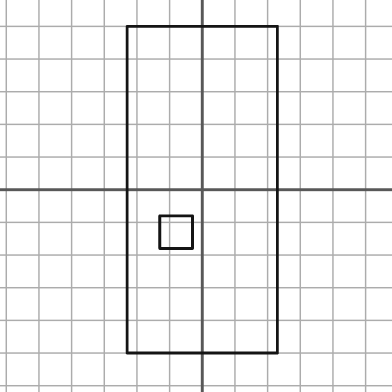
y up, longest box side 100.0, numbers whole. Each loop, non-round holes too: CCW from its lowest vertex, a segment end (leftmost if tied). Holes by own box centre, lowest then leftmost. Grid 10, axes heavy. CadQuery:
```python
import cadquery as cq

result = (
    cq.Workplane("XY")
    .moveTo(-23.0, -50.0)
    .lineTo(23.0, -50.0)
    .lineTo(23.0, 50.0)
    .lineTo(-23.0, 50.0)
    .close()
    .moveTo(-13.0, -18.0)
    .lineTo(-3.0, -18.0)
    .lineTo(-3.0, -8.0)
    .lineTo(-13.0, -8.0)
    .close()
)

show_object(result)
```